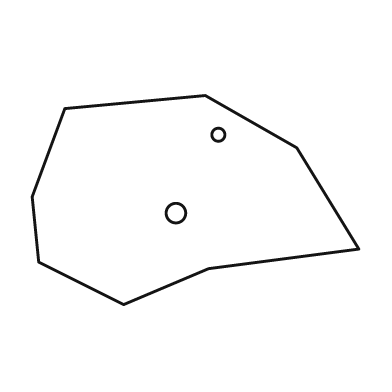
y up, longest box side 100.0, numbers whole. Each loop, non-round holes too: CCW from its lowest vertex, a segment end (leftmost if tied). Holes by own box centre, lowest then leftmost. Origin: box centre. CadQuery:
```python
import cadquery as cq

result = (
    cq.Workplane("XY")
    .moveTo(-22.0, -32.0)
    .lineTo(4.0, -21.0)
    .lineTo(50.0, -15.0)
    .lineTo(31.0, 16.0)
    .lineTo(3.0, 32.0)
    .lineTo(-40.0, 28.0)
    .lineTo(-50.0, 1.0)
    .lineTo(-48.0, -19.0)
    .close()
    .moveTo(-6.0, -4.0)
    .circle(3.0)
    .moveTo(7.0, 20.0)
    .circle(2.0)
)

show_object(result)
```